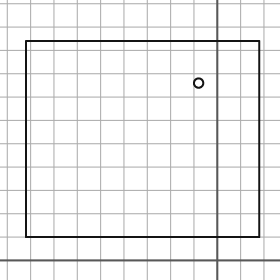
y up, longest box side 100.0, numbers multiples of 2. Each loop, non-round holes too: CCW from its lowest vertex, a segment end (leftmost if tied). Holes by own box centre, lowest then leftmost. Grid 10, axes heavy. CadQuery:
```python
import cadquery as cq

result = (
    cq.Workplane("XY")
    .moveTo(-82.0, 10.0)
    .lineTo(18.0, 10.0)
    .lineTo(18.0, 94.0)
    .lineTo(-82.0, 94.0)
    .close()
    .moveTo(-8.0, 76.0)
    .circle(2.0)
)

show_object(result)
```